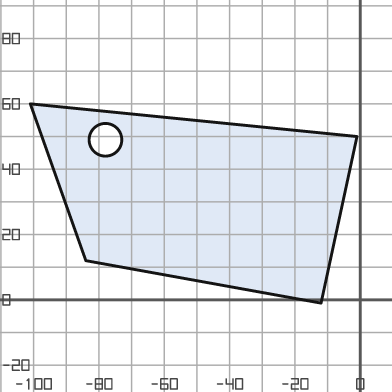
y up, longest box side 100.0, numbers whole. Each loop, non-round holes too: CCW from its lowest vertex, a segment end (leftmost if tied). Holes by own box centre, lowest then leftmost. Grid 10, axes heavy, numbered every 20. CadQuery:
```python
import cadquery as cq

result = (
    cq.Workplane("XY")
    .moveTo(-12.0, -1.0)
    .lineTo(-1.0, 50.0)
    .lineTo(-101.0, 60.0)
    .lineTo(-84.0, 12.0)
    .close()
    .moveTo(-78.0, 49.0)
    .circle(5.0)
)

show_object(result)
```